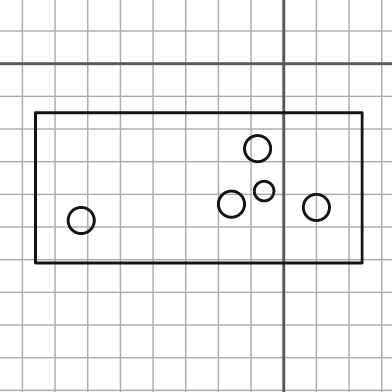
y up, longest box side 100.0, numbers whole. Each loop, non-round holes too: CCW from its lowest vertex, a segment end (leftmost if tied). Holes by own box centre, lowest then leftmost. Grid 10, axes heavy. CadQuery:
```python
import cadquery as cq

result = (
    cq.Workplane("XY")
    .moveTo(-76.0, -61.0)
    .lineTo(24.0, -61.0)
    .lineTo(24.0, -15.0)
    .lineTo(-76.0, -15.0)
    .close()
    .moveTo(-62.0, -48.0)
    .circle(4.0)
    .moveTo(10.0, -44.0)
    .circle(4.0)
    .moveTo(-16.0, -43.0)
    .circle(4.0)
    .moveTo(-6.0, -39.0)
    .circle(3.0)
    .moveTo(-8.0, -26.0)
    .circle(4.0)
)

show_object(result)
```